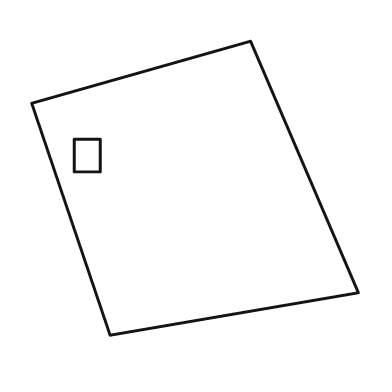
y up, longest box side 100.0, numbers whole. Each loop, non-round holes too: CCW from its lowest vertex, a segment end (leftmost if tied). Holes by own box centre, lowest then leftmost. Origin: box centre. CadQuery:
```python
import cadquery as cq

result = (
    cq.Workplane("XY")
    .moveTo(-26.0, -45.0)
    .lineTo(50.0, -32.0)
    .lineTo(17.0, 45.0)
    .lineTo(-50.0, 26.0)
    .close()
    .moveTo(-37.0, 5.0)
    .lineTo(-29.0, 5.0)
    .lineTo(-29.0, 15.0)
    .lineTo(-37.0, 15.0)
    .close()
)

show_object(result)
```